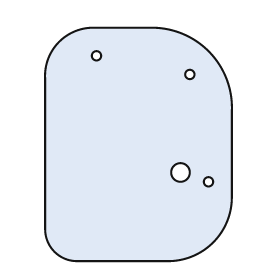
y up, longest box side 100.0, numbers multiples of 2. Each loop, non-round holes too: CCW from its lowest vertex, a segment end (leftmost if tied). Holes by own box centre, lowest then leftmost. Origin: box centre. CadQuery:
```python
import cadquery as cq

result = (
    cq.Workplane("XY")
    .moveTo(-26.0, -50.0)
    .lineTo(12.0, -50.0)
    .threePointArc((32.0, -42.0), (40.0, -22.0))
    .lineTo(40.0, 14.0)
    .threePointArc((30.0, 40.0), (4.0, 50.0))
    .lineTo(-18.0, 50.0)
    .threePointArc((-34.0, 44.0), (-40.0, 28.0))
    .lineTo(-40.0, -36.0)
    .threePointArc((-36.0, -46.0), (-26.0, -50.0))
    .close()
    .moveTo(30.0, -16.0)
    .circle(2.0)
    .moveTo(18.0, -12.0)
    .circle(4.0)
    .moveTo(22.0, 30.0)
    .circle(2.0)
    .moveTo(-18.0, 38.0)
    .circle(2.0)
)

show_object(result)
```